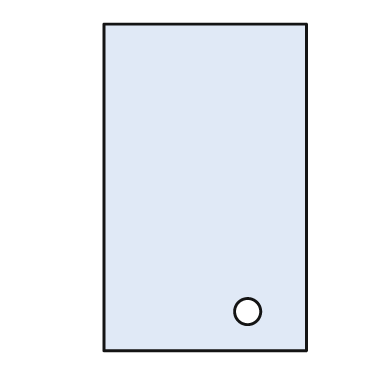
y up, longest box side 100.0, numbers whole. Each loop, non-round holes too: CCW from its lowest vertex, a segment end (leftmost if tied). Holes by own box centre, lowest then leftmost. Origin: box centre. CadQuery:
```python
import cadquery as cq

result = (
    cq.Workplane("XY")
    .moveTo(-31.0, -50.0)
    .lineTo(31.0, -50.0)
    .lineTo(31.0, 50.0)
    .lineTo(-31.0, 50.0)
    .close()
    .moveTo(13.0, -38.0)
    .circle(4.0)
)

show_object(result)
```